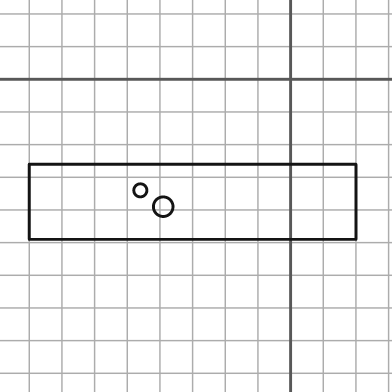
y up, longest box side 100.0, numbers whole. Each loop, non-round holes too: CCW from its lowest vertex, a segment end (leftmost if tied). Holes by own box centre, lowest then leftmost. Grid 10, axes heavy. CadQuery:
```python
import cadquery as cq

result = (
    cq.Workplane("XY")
    .moveTo(-80.0, -49.0)
    .lineTo(20.0, -49.0)
    .lineTo(20.0, -26.0)
    .lineTo(-80.0, -26.0)
    .close()
    .moveTo(-39.0, -39.0)
    .circle(3.0)
    .moveTo(-46.0, -34.0)
    .circle(2.0)
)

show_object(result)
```